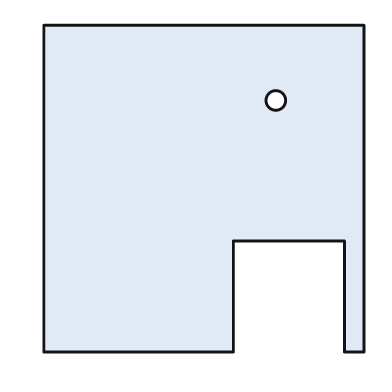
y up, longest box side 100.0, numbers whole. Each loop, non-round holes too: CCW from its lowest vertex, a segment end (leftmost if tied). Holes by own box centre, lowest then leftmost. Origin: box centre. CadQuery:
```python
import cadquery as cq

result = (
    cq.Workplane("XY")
    .moveTo(-49.0, -50.0)
    .lineTo(9.0, -50.0)
    .lineTo(9.0, -16.0)
    .lineTo(43.0, -16.0)
    .lineTo(43.0, -50.0)
    .lineTo(49.0, -50.0)
    .lineTo(49.0, 50.0)
    .lineTo(-49.0, 50.0)
    .close()
    .moveTo(22.0, 27.0)
    .circle(3.0)
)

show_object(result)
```